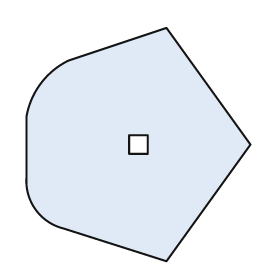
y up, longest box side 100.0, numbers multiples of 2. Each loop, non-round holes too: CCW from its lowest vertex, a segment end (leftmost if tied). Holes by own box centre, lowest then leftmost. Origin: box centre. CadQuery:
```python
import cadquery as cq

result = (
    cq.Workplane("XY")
    .moveTo(12.0, -50.0)
    .lineTo(48.0, 0.0)
    .lineTo(12.0, 50.0)
    .lineTo(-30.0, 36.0)
    .threePointArc((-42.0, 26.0), (-48.0, 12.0))
    .lineTo(-48.0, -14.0)
    .threePointArc((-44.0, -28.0), (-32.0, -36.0))
    .close()
    .moveTo(-4.0, -4.0)
    .lineTo(4.0, -4.0)
    .lineTo(4.0, 4.0)
    .lineTo(-4.0, 4.0)
    .close()
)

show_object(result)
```